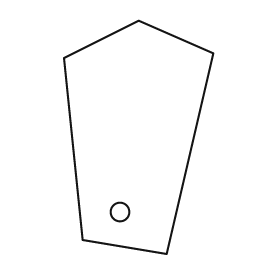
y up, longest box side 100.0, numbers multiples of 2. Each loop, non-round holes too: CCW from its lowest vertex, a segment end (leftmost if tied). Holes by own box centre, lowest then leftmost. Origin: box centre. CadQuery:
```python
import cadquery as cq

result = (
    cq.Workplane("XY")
    .moveTo(12.0, -50.0)
    .lineTo(32.0, 36.0)
    .lineTo(0.0, 50.0)
    .lineTo(-32.0, 34.0)
    .lineTo(-24.0, -44.0)
    .close()
    .moveTo(-8.0, -32.0)
    .circle(4.0)
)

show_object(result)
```